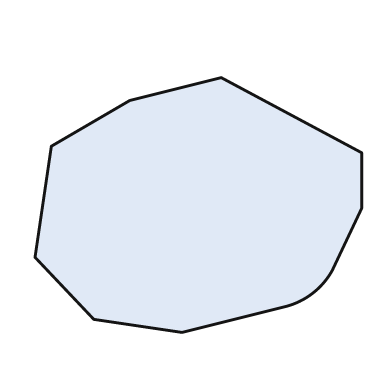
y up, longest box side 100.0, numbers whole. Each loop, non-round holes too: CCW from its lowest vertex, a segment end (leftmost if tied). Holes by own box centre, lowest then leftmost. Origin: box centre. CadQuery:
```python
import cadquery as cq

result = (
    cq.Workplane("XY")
    .moveTo(-5.0, -39.0)
    .lineTo(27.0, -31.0)
    .threePointArc((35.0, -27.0), (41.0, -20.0))
    .lineTo(50.0, -1.0)
    .lineTo(50.0, 16.0)
    .lineTo(7.0, 39.0)
    .lineTo(-21.0, 32.0)
    .lineTo(-45.0, 18.0)
    .lineTo(-50.0, -16.0)
    .lineTo(-32.0, -35.0)
    .close()
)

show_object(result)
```